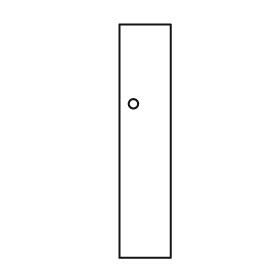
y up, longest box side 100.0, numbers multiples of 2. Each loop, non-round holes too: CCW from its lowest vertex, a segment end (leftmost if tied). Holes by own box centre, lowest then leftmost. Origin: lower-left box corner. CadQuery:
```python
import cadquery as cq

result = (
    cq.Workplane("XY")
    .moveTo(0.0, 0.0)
    .lineTo(22.0, 0.0)
    .lineTo(22.0, 100.0)
    .lineTo(0.0, 100.0)
    .close()
    .moveTo(6.0, 66.0)
    .circle(2.0)
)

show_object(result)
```